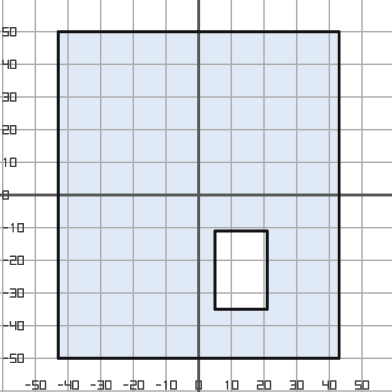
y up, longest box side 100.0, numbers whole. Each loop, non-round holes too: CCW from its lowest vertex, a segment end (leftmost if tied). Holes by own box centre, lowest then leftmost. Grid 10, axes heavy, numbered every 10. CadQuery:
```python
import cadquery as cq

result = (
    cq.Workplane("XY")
    .moveTo(-43.0, -50.0)
    .lineTo(43.0, -50.0)
    .lineTo(43.0, 50.0)
    .lineTo(-43.0, 50.0)
    .close()
    .moveTo(5.0, -35.0)
    .lineTo(21.0, -35.0)
    .lineTo(21.0, -11.0)
    .lineTo(5.0, -11.0)
    .close()
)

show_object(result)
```